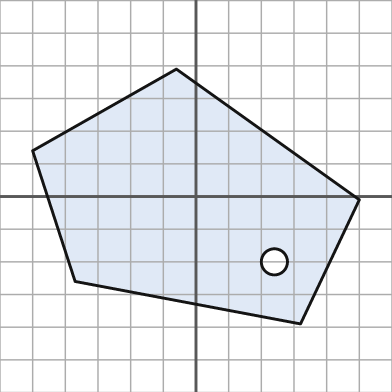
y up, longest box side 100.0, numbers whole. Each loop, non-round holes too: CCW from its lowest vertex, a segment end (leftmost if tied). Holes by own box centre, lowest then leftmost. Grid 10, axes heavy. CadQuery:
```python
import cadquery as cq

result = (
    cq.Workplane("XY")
    .moveTo(32.0, -39.0)
    .lineTo(50.0, -1.0)
    .lineTo(-6.0, 39.0)
    .lineTo(-50.0, 14.0)
    .lineTo(-37.0, -26.0)
    .close()
    .moveTo(24.0, -20.0)
    .circle(4.0)
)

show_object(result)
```